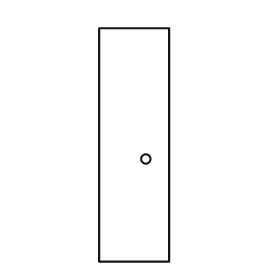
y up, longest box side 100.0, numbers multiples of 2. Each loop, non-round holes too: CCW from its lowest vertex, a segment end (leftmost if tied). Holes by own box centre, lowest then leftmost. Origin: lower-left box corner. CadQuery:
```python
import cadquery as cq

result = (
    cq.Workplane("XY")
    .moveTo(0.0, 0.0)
    .lineTo(30.0, 0.0)
    .lineTo(30.0, 100.0)
    .lineTo(0.0, 100.0)
    .close()
    .moveTo(20.0, 44.0)
    .circle(2.0)
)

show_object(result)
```